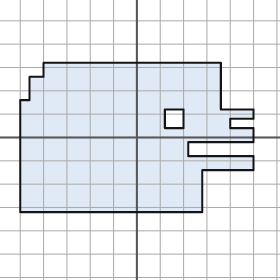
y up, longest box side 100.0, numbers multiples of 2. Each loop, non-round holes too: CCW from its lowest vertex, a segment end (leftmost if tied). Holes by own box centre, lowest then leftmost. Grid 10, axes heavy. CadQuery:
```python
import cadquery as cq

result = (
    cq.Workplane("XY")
    .moveTo(-50.0, -32.0)
    .lineTo(28.0, -32.0)
    .lineTo(28.0, -14.0)
    .lineTo(50.0, -14.0)
    .lineTo(50.0, -8.0)
    .lineTo(22.0, -8.0)
    .lineTo(22.0, -2.0)
    .lineTo(50.0, -2.0)
    .lineTo(50.0, 4.0)
    .lineTo(40.0, 4.0)
    .lineTo(40.0, 8.0)
    .lineTo(50.0, 8.0)
    .lineTo(50.0, 12.0)
    .lineTo(36.0, 12.0)
    .lineTo(36.0, 32.0)
    .lineTo(-40.0, 32.0)
    .lineTo(-40.0, 26.0)
    .lineTo(-46.0, 26.0)
    .lineTo(-46.0, 16.0)
    .lineTo(-50.0, 16.0)
    .close()
    .moveTo(12.0, 4.0)
    .lineTo(20.0, 4.0)
    .lineTo(20.0, 12.0)
    .lineTo(12.0, 12.0)
    .close()
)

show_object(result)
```